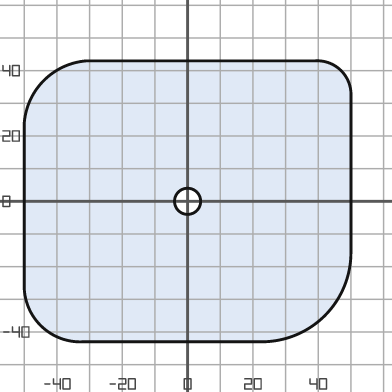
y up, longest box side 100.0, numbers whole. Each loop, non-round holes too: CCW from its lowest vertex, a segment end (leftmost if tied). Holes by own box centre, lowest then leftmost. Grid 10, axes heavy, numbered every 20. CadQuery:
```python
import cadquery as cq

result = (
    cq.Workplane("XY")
    .moveTo(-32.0, -43.0)
    .lineTo(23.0, -43.0)
    .threePointArc((42.0, -35.0), (50.0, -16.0))
    .lineTo(50.0, 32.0)
    .threePointArc((47.0, 40.0), (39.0, 43.0))
    .lineTo(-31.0, 43.0)
    .threePointArc((-44.0, 37.0), (-50.0, 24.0))
    .lineTo(-50.0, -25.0)
    .threePointArc((-45.0, -38.0), (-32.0, -43.0))
    .close()
    .moveTo(0.0, 0.0)
    .circle(4.0)
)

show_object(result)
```